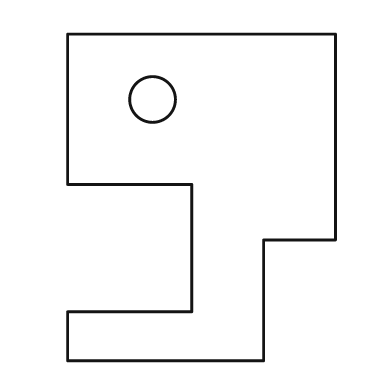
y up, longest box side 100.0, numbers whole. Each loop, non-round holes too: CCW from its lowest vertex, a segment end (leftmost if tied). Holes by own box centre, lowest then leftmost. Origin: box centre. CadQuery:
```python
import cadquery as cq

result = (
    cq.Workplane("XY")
    .moveTo(-41.0, -50.0)
    .lineTo(19.0, -50.0)
    .lineTo(19.0, -13.0)
    .lineTo(41.0, -13.0)
    .lineTo(41.0, 50.0)
    .lineTo(-41.0, 50.0)
    .lineTo(-41.0, 4.0)
    .lineTo(-3.0, 4.0)
    .lineTo(-3.0, -35.0)
    .lineTo(-41.0, -35.0)
    .close()
    .moveTo(-15.0, 30.0)
    .circle(7.0)
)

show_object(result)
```